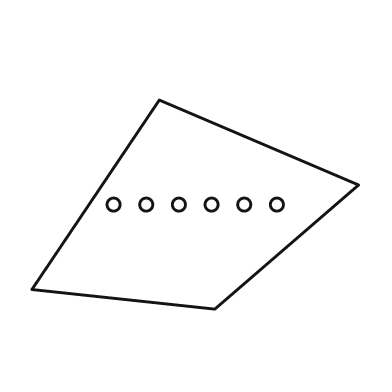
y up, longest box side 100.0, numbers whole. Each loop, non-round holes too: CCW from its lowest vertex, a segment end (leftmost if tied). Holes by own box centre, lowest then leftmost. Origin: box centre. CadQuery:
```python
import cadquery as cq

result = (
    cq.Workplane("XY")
    .moveTo(6.0, -32.0)
    .lineTo(50.0, 6.0)
    .lineTo(-11.0, 32.0)
    .lineTo(-50.0, -26.0)
    .close()
    .moveTo(-25.0, 0.0)
    .circle(2.0)
    .moveTo(-15.0, 0.0)
    .circle(2.0)
    .moveTo(-5.0, 0.0)
    .circle(2.0)
    .moveTo(5.0, 0.0)
    .circle(2.0)
    .moveTo(15.0, 0.0)
    .circle(2.0)
    .moveTo(25.0, 0.0)
    .circle(2.0)
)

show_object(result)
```